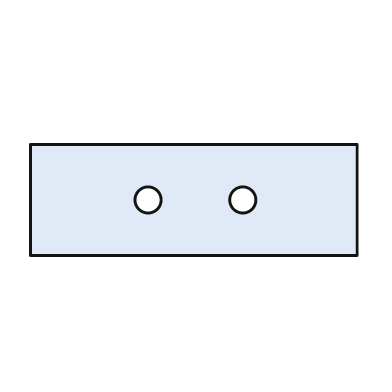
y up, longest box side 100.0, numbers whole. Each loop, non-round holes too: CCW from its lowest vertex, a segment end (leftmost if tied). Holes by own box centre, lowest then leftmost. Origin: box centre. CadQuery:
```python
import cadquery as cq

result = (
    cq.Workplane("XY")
    .moveTo(-50.0, -17.0)
    .lineTo(50.0, -17.0)
    .lineTo(50.0, 17.0)
    .lineTo(-50.0, 17.0)
    .close()
    .moveTo(-14.0, 0.0)
    .circle(4.0)
    .moveTo(15.0, 0.0)
    .circle(4.0)
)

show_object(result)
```